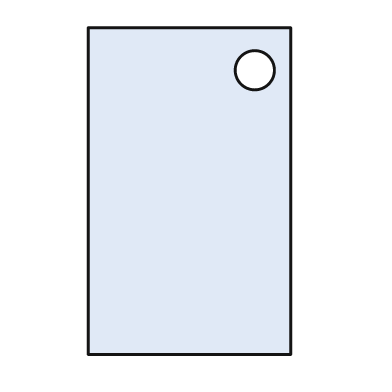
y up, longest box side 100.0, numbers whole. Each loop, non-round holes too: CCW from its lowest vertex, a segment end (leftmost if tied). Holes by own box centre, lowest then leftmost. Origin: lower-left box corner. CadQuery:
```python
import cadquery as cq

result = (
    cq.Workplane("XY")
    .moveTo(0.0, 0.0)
    .lineTo(62.0, 0.0)
    .lineTo(62.0, 100.0)
    .lineTo(0.0, 100.0)
    .close()
    .moveTo(51.0, 87.0)
    .circle(6.0)
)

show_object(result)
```